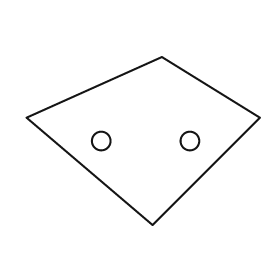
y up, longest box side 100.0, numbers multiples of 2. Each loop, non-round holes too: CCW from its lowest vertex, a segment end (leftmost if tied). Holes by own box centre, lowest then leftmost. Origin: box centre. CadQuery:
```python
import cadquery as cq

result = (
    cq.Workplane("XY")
    .moveTo(4.0, -36.0)
    .lineTo(50.0, 10.0)
    .lineTo(8.0, 36.0)
    .lineTo(-50.0, 10.0)
    .close()
    .moveTo(-18.0, 0.0)
    .circle(4.0)
    .moveTo(20.0, 0.0)
    .circle(4.0)
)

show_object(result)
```